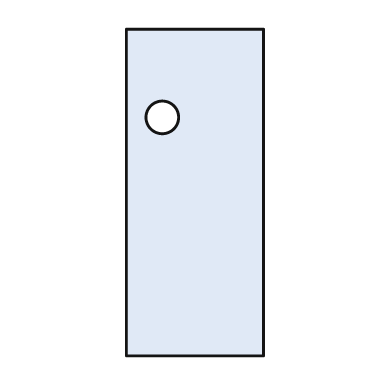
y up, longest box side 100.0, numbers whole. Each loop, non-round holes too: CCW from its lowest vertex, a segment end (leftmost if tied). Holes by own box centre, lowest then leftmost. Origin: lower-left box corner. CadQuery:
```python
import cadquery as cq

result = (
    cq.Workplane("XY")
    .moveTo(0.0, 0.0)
    .lineTo(42.0, 0.0)
    .lineTo(42.0, 100.0)
    .lineTo(0.0, 100.0)
    .close()
    .moveTo(11.0, 73.0)
    .circle(5.0)
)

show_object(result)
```